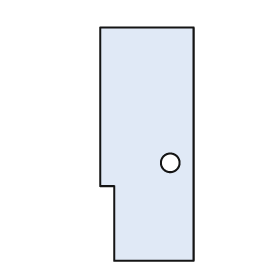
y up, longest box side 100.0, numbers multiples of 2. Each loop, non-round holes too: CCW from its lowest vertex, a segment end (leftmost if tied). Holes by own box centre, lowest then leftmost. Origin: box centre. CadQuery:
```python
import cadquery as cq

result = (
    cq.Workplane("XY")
    .moveTo(-14.0, -50.0)
    .lineTo(20.0, -50.0)
    .lineTo(20.0, 50.0)
    .lineTo(-20.0, 50.0)
    .lineTo(-20.0, -18.0)
    .lineTo(-14.0, -18.0)
    .close()
    .moveTo(10.0, -8.0)
    .circle(4.0)
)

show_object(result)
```